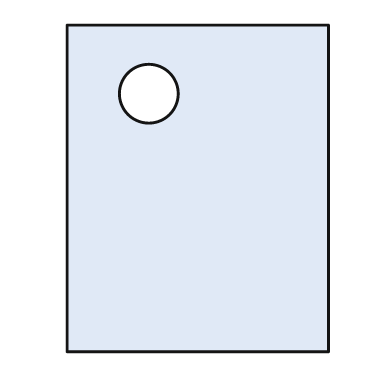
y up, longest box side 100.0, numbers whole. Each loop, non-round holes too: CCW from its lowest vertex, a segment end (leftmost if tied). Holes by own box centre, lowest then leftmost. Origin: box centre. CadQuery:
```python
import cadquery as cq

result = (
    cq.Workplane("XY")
    .moveTo(-40.0, -50.0)
    .lineTo(40.0, -50.0)
    .lineTo(40.0, 50.0)
    .lineTo(-40.0, 50.0)
    .close()
    .moveTo(-15.0, 29.0)
    .circle(9.0)
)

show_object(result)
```